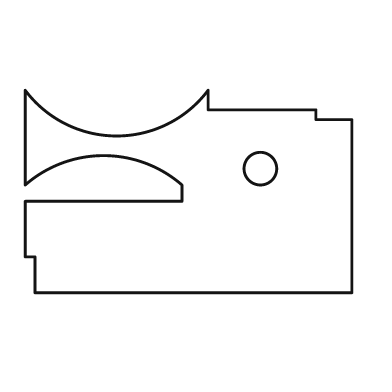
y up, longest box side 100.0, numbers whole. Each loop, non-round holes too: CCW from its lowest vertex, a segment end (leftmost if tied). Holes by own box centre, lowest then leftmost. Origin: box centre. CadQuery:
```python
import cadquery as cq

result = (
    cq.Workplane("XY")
    .moveTo(-47.0, -31.0)
    .lineTo(50.0, -31.0)
    .lineTo(50.0, 22.0)
    .lineTo(39.0, 22.0)
    .lineTo(39.0, 25.0)
    .lineTo(6.0, 25.0)
    .lineTo(6.0, 31.0)
    .threePointArc((-22.0, 17.0), (-50.0, 31.0))
    .lineTo(-50.0, 2.0)
    .threePointArc((-26.0, 11.0), (-2.0, 2.0))
    .lineTo(-2.0, -3.0)
    .lineTo(-50.0, -3.0)
    .lineTo(-50.0, -20.0)
    .lineTo(-47.0, -20.0)
    .close()
    .moveTo(22.0, 7.0)
    .circle(5.0)
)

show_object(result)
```